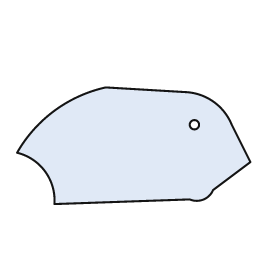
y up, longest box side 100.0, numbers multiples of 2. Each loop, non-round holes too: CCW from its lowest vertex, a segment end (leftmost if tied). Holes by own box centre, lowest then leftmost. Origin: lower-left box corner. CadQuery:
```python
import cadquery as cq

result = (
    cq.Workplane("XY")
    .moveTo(16.0, 0.0)
    .lineTo(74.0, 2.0)
    .threePointArc((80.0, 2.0), (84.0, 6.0))
    .lineTo(100.0, 18.0)
    .lineTo(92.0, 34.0)
    .threePointArc((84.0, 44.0), (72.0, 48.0))
    .lineTo(38.0, 50.0)
    .threePointArc((16.0, 40.0), (0.0, 22.0))
    .threePointArc((12.0, 14.0), (16.0, 0.0))
    .close()
    .moveTo(76.0, 34.0)
    .circle(2.0)
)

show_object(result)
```